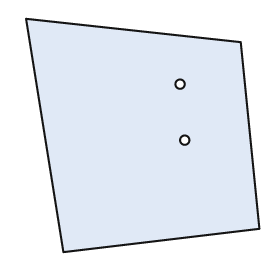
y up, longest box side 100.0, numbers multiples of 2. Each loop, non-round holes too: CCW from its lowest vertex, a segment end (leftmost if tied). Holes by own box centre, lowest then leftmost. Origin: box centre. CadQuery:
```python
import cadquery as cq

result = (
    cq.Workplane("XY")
    .moveTo(-34.0, -50.0)
    .lineTo(50.0, -40.0)
    .lineTo(42.0, 40.0)
    .lineTo(-50.0, 50.0)
    .close()
    .moveTo(18.0, -2.0)
    .circle(2.0)
    .moveTo(16.0, 22.0)
    .circle(2.0)
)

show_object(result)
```